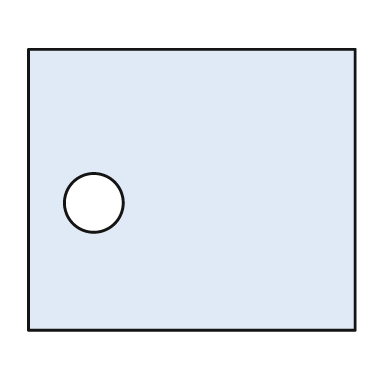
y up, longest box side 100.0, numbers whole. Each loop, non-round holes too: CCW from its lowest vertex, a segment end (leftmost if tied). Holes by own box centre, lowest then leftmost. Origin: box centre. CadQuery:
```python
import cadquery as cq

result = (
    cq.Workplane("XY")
    .moveTo(-50.0, -43.0)
    .lineTo(50.0, -43.0)
    .lineTo(50.0, 43.0)
    .lineTo(-50.0, 43.0)
    .close()
    .moveTo(-30.0, -4.0)
    .circle(9.0)
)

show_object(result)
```